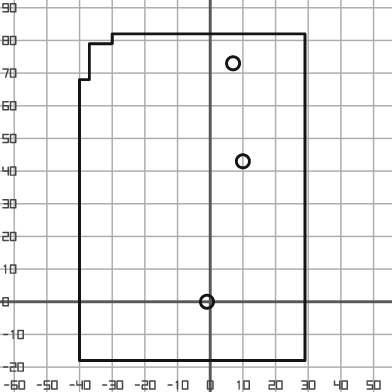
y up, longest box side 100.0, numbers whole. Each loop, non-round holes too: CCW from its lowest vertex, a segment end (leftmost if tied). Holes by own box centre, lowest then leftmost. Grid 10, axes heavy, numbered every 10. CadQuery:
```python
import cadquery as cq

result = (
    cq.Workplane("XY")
    .moveTo(-40.0, -18.0)
    .lineTo(29.0, -18.0)
    .lineTo(29.0, 82.0)
    .lineTo(-30.0, 82.0)
    .lineTo(-30.0, 79.0)
    .lineTo(-37.0, 79.0)
    .lineTo(-37.0, 68.0)
    .lineTo(-40.0, 68.0)
    .close()
    .moveTo(-1.0, 0.0)
    .circle(2.0)
    .moveTo(10.0, 43.0)
    .circle(2.0)
    .moveTo(7.0, 73.0)
    .circle(2.0)
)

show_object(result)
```